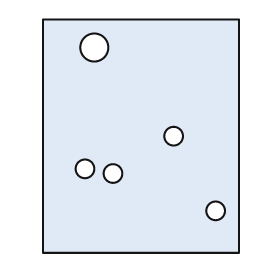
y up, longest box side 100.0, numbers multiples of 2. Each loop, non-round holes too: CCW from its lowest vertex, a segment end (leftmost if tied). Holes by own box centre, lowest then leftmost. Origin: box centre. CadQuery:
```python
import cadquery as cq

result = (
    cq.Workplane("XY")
    .moveTo(-42.0, -50.0)
    .lineTo(42.0, -50.0)
    .lineTo(42.0, 50.0)
    .lineTo(-42.0, 50.0)
    .close()
    .moveTo(32.0, -32.0)
    .circle(4.0)
    .moveTo(-12.0, -16.0)
    .circle(4.0)
    .moveTo(-24.0, -14.0)
    .circle(4.0)
    .moveTo(14.0, 0.0)
    .circle(4.0)
    .moveTo(-20.0, 38.0)
    .circle(6.0)
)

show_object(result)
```